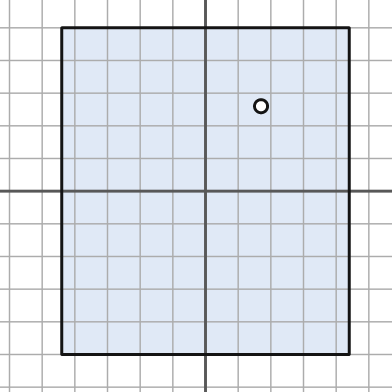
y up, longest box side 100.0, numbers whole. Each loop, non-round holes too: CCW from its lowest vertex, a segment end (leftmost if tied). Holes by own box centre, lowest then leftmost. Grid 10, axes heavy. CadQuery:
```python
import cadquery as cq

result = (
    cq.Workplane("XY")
    .moveTo(-44.0, -50.0)
    .lineTo(44.0, -50.0)
    .lineTo(44.0, 50.0)
    .lineTo(-44.0, 50.0)
    .close()
    .moveTo(17.0, 26.0)
    .circle(2.0)
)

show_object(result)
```